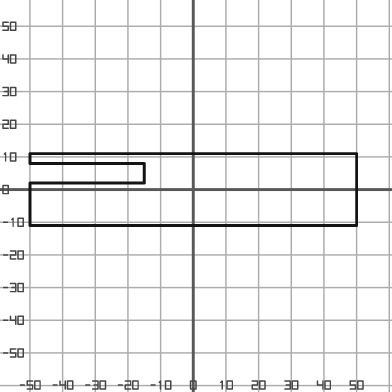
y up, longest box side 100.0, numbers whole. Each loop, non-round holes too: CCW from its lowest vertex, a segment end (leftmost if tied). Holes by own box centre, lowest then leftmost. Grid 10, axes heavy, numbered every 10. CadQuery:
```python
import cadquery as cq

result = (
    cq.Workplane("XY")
    .moveTo(-50.0, -11.0)
    .lineTo(50.0, -11.0)
    .lineTo(50.0, 11.0)
    .lineTo(-50.0, 11.0)
    .lineTo(-50.0, 8.0)
    .lineTo(-15.0, 8.0)
    .lineTo(-15.0, 2.0)
    .lineTo(-50.0, 2.0)
    .close()
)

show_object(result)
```